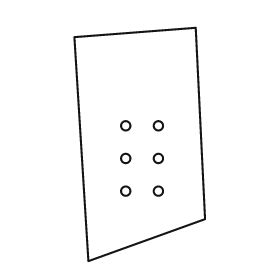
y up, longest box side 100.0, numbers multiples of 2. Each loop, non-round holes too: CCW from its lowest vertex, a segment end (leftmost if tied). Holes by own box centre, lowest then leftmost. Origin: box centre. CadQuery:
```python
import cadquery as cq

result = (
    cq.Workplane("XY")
    .moveTo(-22.0, -50.0)
    .lineTo(28.0, -32.0)
    .lineTo(24.0, 50.0)
    .lineTo(-28.0, 46.0)
    .close()
    .moveTo(-6.0, -20.0)
    .circle(2.0)
    .moveTo(8.0, -20.0)
    .circle(2.0)
    .moveTo(-6.0, -6.0)
    .circle(2.0)
    .moveTo(8.0, -6.0)
    .circle(2.0)
    .moveTo(-6.0, 8.0)
    .circle(2.0)
    .moveTo(8.0, 8.0)
    .circle(2.0)
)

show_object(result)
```